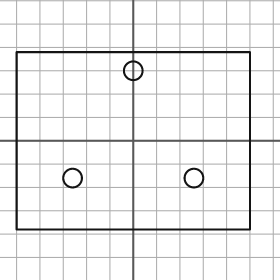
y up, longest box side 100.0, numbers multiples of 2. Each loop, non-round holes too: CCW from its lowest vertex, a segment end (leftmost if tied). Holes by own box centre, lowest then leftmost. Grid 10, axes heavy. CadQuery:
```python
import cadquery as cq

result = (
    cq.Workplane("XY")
    .moveTo(-50.0, -38.0)
    .lineTo(50.0, -38.0)
    .lineTo(50.0, 38.0)
    .lineTo(-50.0, 38.0)
    .close()
    .moveTo(-26.0, -16.0)
    .circle(4.0)
    .moveTo(26.0, -16.0)
    .circle(4.0)
    .moveTo(0.0, 30.0)
    .circle(4.0)
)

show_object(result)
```